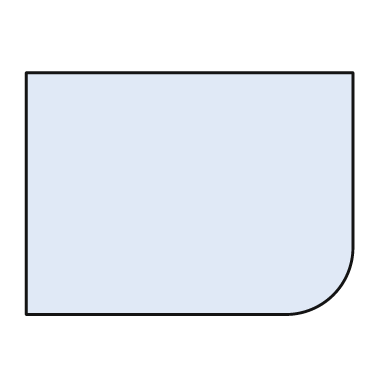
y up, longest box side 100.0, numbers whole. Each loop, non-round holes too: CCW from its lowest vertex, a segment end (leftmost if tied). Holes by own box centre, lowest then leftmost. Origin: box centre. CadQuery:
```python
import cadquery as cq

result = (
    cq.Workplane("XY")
    .moveTo(-50.0, -37.0)
    .lineTo(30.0, -37.0)
    .threePointArc((44.0, -31.0), (50.0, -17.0))
    .lineTo(50.0, 37.0)
    .lineTo(-50.0, 37.0)
    .close()
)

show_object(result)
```